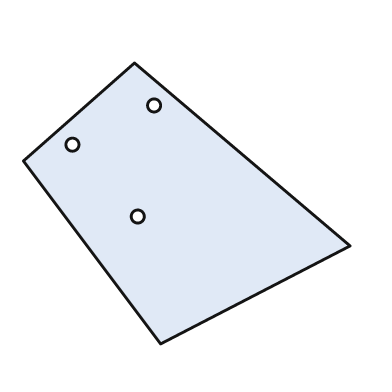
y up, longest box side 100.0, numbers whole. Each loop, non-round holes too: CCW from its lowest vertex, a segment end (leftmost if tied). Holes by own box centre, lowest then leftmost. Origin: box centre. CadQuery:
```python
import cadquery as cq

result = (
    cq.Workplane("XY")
    .moveTo(-8.0, -43.0)
    .lineTo(50.0, -13.0)
    .lineTo(-16.0, 43.0)
    .lineTo(-50.0, 13.0)
    .close()
    .moveTo(-15.0, -4.0)
    .circle(2.0)
    .moveTo(-35.0, 18.0)
    .circle(2.0)
    .moveTo(-10.0, 30.0)
    .circle(2.0)
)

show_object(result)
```